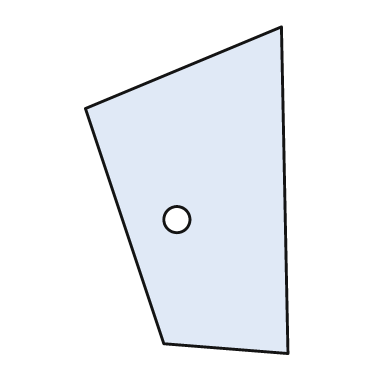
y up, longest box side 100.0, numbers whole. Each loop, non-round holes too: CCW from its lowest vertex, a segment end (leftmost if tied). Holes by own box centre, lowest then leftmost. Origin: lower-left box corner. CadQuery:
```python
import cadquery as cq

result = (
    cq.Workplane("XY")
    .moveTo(62.0, 0.0)
    .lineTo(60.0, 100.0)
    .lineTo(0.0, 75.0)
    .lineTo(24.0, 3.0)
    .close()
    .moveTo(28.0, 41.0)
    .circle(4.0)
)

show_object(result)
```